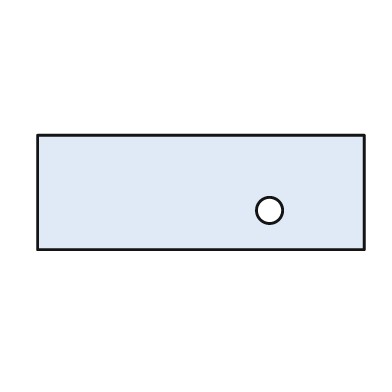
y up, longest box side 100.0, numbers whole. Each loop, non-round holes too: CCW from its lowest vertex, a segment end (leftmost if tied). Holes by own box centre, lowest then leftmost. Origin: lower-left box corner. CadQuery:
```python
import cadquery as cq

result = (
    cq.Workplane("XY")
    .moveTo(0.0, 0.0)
    .lineTo(100.0, 0.0)
    .lineTo(100.0, 35.0)
    .lineTo(0.0, 35.0)
    .close()
    .moveTo(71.0, 12.0)
    .circle(4.0)
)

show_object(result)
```